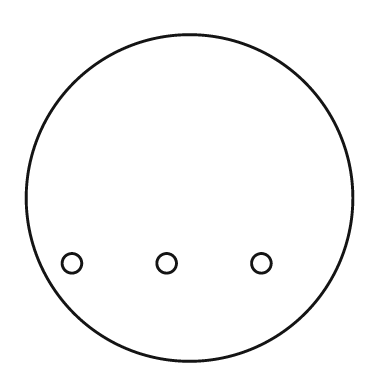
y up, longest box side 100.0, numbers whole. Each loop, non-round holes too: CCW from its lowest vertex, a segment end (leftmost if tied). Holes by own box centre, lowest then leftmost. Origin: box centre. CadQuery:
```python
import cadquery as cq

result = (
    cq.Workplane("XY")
    .moveTo(0.0, 0.0)
    .circle(50.0)
    .moveTo(-36.0, -20.0)
    .circle(3.0)
    .moveTo(-7.0, -20.0)
    .circle(3.0)
    .moveTo(22.0, -20.0)
    .circle(3.0)
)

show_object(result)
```